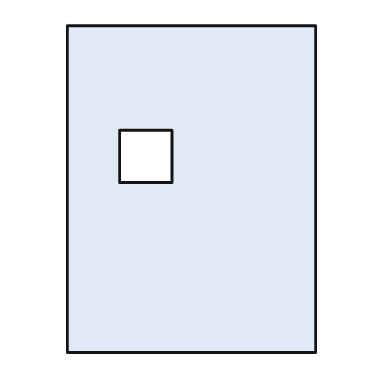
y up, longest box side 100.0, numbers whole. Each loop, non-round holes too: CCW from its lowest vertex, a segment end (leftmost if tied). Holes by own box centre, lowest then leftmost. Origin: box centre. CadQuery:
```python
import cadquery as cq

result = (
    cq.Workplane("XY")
    .moveTo(-38.0, -50.0)
    .lineTo(38.0, -50.0)
    .lineTo(38.0, 50.0)
    .lineTo(-38.0, 50.0)
    .close()
    .moveTo(-22.0, 2.0)
    .lineTo(-6.0, 2.0)
    .lineTo(-6.0, 18.0)
    .lineTo(-22.0, 18.0)
    .close()
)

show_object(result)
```